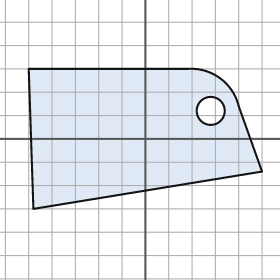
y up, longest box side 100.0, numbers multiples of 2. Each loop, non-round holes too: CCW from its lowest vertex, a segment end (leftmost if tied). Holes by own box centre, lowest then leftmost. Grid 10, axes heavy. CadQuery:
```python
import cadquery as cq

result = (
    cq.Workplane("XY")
    .moveTo(-48.0, -30.0)
    .lineTo(50.0, -14.0)
    .lineTo(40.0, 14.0)
    .threePointArc((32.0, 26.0), (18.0, 30.0))
    .lineTo(-50.0, 30.0)
    .close()
    .moveTo(28.0, 12.0)
    .circle(6.0)
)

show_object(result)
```